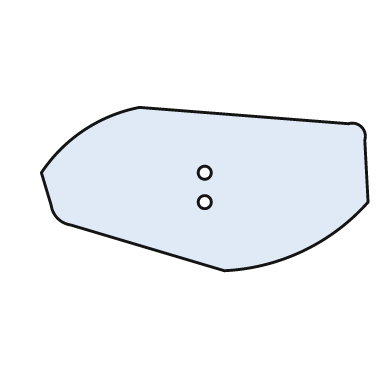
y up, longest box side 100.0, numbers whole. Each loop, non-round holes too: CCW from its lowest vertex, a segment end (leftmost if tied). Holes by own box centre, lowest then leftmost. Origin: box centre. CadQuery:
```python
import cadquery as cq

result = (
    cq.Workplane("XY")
    .moveTo(6.0, -25.0)
    .threePointArc((30.0, -19.0), (50.0, -4.0))
    .lineTo(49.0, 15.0)
    .threePointArc((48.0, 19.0), (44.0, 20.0))
    .lineTo(-20.0, 25.0)
    .threePointArc((-37.0, 18.0), (-50.0, 5.0))
    .lineTo(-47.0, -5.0)
    .threePointArc((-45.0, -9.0), (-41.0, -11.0))
    .close()
    .moveTo(0.0, -4.0)
    .circle(2.0)
    .moveTo(0.0, 5.0)
    .circle(2.0)
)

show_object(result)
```